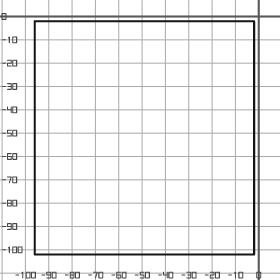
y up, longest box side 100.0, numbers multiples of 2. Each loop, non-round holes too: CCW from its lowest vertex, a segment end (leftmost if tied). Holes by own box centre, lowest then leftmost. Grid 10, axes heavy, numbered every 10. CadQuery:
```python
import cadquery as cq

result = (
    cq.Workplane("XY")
    .moveTo(-96.0, -102.0)
    .lineTo(-2.0, -102.0)
    .lineTo(-2.0, -2.0)
    .lineTo(-96.0, -2.0)
    .close()
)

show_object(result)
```